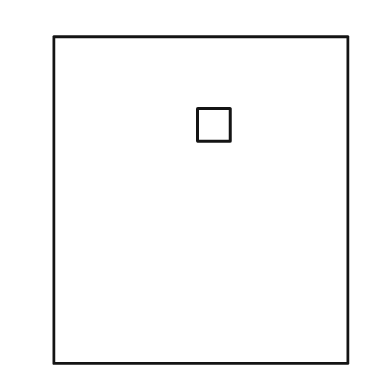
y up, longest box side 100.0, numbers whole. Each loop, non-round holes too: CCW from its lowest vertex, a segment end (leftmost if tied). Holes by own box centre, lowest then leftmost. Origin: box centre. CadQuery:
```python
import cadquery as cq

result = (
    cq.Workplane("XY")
    .moveTo(-45.0, -50.0)
    .lineTo(45.0, -50.0)
    .lineTo(45.0, 50.0)
    .lineTo(-45.0, 50.0)
    .close()
    .moveTo(-1.0, 18.0)
    .lineTo(9.0, 18.0)
    .lineTo(9.0, 28.0)
    .lineTo(-1.0, 28.0)
    .close()
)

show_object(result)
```